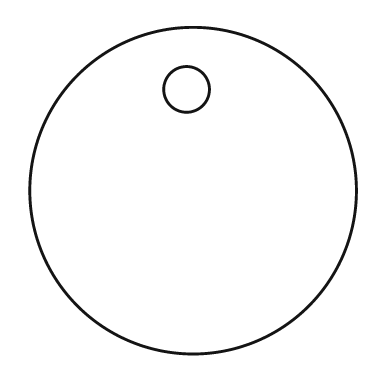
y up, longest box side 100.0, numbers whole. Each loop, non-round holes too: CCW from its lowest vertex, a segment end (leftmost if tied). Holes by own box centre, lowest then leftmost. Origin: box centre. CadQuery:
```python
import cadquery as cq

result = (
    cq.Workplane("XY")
    .moveTo(0.0, 0.0)
    .circle(50.0)
    .moveTo(-2.0, 31.0)
    .circle(7.0)
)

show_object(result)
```